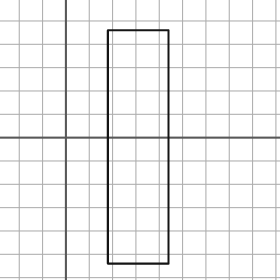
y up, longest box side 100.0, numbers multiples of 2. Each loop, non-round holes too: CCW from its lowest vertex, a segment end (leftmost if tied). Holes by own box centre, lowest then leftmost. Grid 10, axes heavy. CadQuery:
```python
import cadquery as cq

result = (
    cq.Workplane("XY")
    .moveTo(18.0, -54.0)
    .lineTo(44.0, -54.0)
    .lineTo(44.0, 46.0)
    .lineTo(18.0, 46.0)
    .close()
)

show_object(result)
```